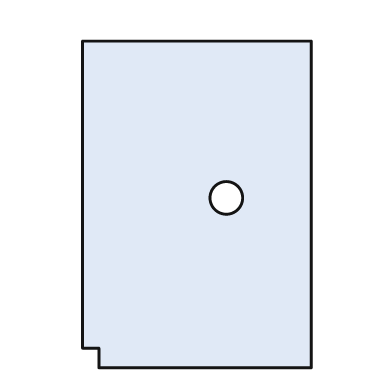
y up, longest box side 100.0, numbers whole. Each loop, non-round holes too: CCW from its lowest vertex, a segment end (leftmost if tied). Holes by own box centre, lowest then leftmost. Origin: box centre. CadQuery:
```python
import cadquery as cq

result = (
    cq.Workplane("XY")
    .moveTo(-30.0, -50.0)
    .lineTo(35.0, -50.0)
    .lineTo(35.0, 50.0)
    .lineTo(-35.0, 50.0)
    .lineTo(-35.0, -44.0)
    .lineTo(-30.0, -44.0)
    .close()
    .moveTo(9.0, 2.0)
    .circle(5.0)
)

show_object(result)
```